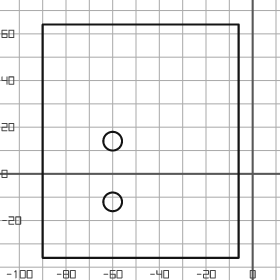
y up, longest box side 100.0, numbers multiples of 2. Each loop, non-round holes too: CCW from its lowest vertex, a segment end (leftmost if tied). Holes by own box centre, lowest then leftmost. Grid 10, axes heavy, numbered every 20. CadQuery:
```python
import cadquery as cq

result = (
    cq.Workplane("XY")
    .moveTo(-90.0, -36.0)
    .lineTo(-6.0, -36.0)
    .lineTo(-6.0, 64.0)
    .lineTo(-90.0, 64.0)
    .close()
    .moveTo(-60.0, -12.0)
    .circle(4.0)
    .moveTo(-60.0, 14.0)
    .circle(4.0)
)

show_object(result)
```